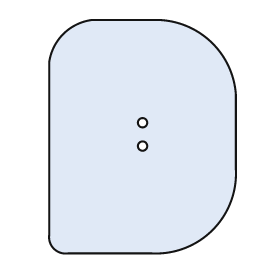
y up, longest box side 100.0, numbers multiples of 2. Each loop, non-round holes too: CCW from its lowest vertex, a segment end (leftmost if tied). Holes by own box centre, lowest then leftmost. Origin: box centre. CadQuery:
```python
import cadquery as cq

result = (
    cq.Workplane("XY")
    .moveTo(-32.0, -50.0)
    .lineTo(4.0, -50.0)
    .threePointArc((30.0, -40.0), (40.0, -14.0))
    .lineTo(40.0, 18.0)
    .threePointArc((30.0, 40.0), (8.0, 50.0))
    .lineTo(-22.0, 50.0)
    .threePointArc((-34.0, 44.0), (-40.0, 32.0))
    .lineTo(-40.0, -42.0)
    .threePointArc((-38.0, -48.0), (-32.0, -50.0))
    .close()
    .moveTo(0.0, -4.0)
    .circle(2.0)
    .moveTo(0.0, 6.0)
    .circle(2.0)
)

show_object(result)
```